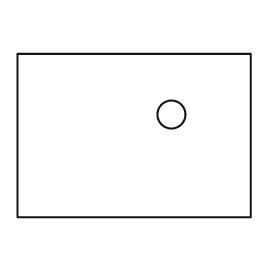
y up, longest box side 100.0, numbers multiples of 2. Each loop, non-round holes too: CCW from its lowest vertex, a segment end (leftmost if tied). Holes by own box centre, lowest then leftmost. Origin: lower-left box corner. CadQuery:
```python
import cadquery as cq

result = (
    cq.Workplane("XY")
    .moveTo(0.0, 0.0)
    .lineTo(100.0, 0.0)
    .lineTo(100.0, 70.0)
    .lineTo(0.0, 70.0)
    .close()
    .moveTo(66.0, 44.0)
    .circle(6.0)
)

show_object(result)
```